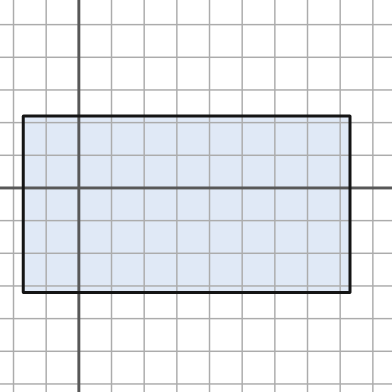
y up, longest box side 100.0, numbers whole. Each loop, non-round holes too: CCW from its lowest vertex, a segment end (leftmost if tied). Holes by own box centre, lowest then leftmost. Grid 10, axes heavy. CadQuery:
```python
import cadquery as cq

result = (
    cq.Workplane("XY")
    .moveTo(-17.0, -32.0)
    .lineTo(83.0, -32.0)
    .lineTo(83.0, 22.0)
    .lineTo(-17.0, 22.0)
    .close()
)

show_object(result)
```